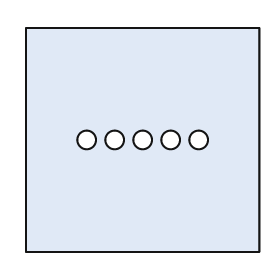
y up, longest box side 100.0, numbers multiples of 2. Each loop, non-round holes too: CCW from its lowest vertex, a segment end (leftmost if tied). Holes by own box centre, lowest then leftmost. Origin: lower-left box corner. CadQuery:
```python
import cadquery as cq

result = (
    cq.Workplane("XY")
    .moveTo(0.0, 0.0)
    .lineTo(100.0, 0.0)
    .lineTo(100.0, 96.0)
    .lineTo(0.0, 96.0)
    .close()
    .moveTo(26.0, 48.0)
    .circle(4.0)
    .moveTo(38.0, 48.0)
    .circle(4.0)
    .moveTo(50.0, 48.0)
    .circle(4.0)
    .moveTo(62.0, 48.0)
    .circle(4.0)
    .moveTo(74.0, 48.0)
    .circle(4.0)
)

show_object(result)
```